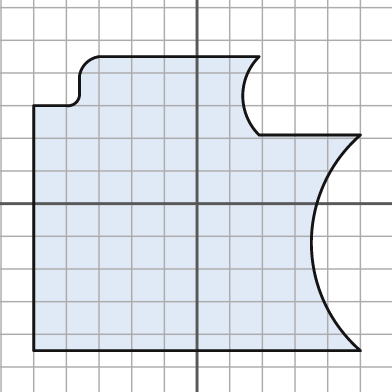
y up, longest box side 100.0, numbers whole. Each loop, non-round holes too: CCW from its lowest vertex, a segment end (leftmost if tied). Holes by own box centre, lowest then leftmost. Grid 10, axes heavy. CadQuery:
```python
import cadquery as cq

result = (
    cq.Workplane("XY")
    .moveTo(-50.0, -45.0)
    .lineTo(50.0, -45.0)
    .threePointArc((35.0, -12.0), (50.0, 21.0))
    .lineTo(19.0, 21.0)
    .threePointArc((14.0, 33.0), (19.0, 45.0))
    .lineTo(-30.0, 45.0)
    .threePointArc((-34.0, 43.0), (-36.0, 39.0))
    .lineTo(-36.0, 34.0)
    .threePointArc((-37.0, 31.0), (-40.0, 30.0))
    .lineTo(-50.0, 30.0)
    .close()
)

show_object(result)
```